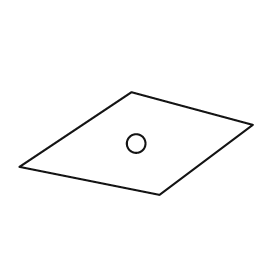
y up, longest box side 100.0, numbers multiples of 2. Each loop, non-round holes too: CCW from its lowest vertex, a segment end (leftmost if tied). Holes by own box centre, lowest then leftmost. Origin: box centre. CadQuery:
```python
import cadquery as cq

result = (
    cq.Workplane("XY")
    .moveTo(10.0, -22.0)
    .lineTo(50.0, 8.0)
    .lineTo(-2.0, 22.0)
    .lineTo(-50.0, -10.0)
    .close()
    .moveTo(0.0, 0.0)
    .circle(4.0)
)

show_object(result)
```